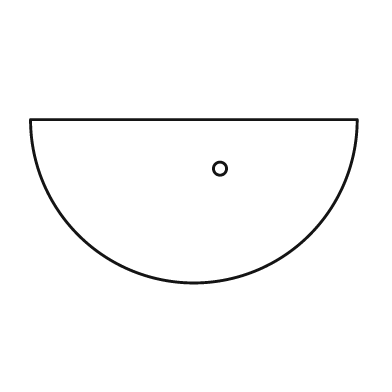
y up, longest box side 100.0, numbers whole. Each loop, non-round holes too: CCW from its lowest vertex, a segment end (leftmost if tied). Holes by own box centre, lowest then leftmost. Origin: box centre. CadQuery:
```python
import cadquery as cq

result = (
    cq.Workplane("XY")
    .moveTo(-50.0, 25.0)
    .threePointArc((0.0, -25.0), (50.0, 25.0))
    .close()
    .moveTo(8.0, 10.0)
    .circle(2.0)
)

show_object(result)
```